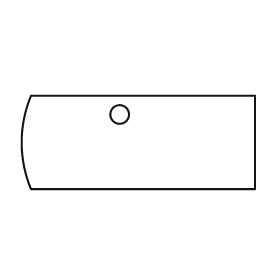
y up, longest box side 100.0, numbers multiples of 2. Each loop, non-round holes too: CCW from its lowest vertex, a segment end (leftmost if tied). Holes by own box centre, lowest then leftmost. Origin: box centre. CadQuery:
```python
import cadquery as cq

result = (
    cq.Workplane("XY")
    .moveTo(-46.0, -20.0)
    .lineTo(50.0, -20.0)
    .lineTo(50.0, 20.0)
    .lineTo(-46.0, 20.0)
    .threePointArc((-50.0, 0.0), (-46.0, -20.0))
    .close()
    .moveTo(-8.0, 12.0)
    .circle(4.0)
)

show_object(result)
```